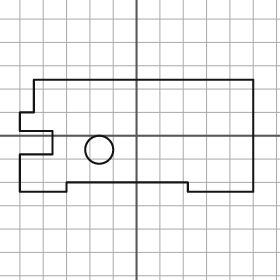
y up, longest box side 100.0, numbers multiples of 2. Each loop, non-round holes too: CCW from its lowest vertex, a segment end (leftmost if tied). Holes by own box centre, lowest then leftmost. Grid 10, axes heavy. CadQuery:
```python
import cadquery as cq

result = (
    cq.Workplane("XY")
    .moveTo(-50.0, -24.0)
    .lineTo(-30.0, -24.0)
    .lineTo(-30.0, -20.0)
    .lineTo(22.0, -20.0)
    .lineTo(22.0, -24.0)
    .lineTo(50.0, -24.0)
    .lineTo(50.0, 24.0)
    .lineTo(-44.0, 24.0)
    .lineTo(-44.0, 10.0)
    .lineTo(-50.0, 10.0)
    .lineTo(-50.0, 2.0)
    .lineTo(-36.0, 2.0)
    .lineTo(-36.0, -8.0)
    .lineTo(-50.0, -8.0)
    .close()
    .moveTo(-16.0, -6.0)
    .circle(6.0)
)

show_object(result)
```